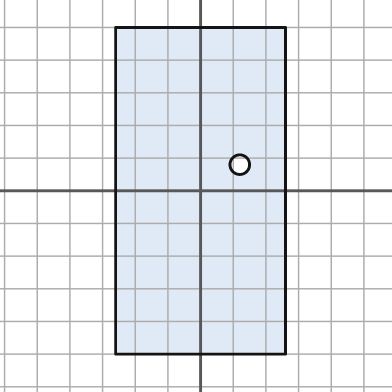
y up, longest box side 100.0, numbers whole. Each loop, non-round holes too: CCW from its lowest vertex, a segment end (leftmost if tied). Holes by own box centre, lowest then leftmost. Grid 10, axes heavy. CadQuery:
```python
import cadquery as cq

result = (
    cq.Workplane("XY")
    .moveTo(-26.0, -50.0)
    .lineTo(26.0, -50.0)
    .lineTo(26.0, 50.0)
    .lineTo(-26.0, 50.0)
    .close()
    .moveTo(12.0, 8.0)
    .circle(3.0)
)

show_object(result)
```